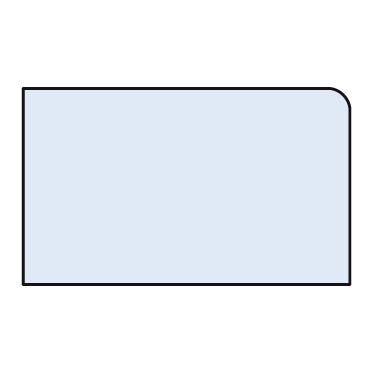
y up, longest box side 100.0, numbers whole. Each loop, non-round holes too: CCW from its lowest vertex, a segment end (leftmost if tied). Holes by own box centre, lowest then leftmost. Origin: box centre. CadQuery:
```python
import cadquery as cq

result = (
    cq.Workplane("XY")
    .moveTo(-50.0, -30.0)
    .lineTo(50.0, -30.0)
    .lineTo(50.0, 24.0)
    .threePointArc((48.0, 28.0), (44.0, 30.0))
    .lineTo(-50.0, 30.0)
    .close()
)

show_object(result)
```